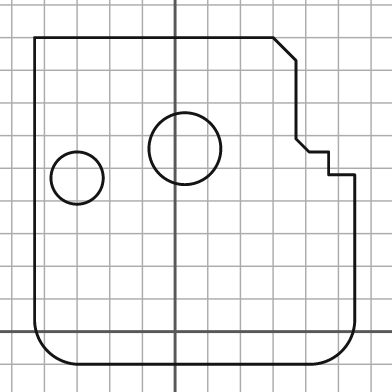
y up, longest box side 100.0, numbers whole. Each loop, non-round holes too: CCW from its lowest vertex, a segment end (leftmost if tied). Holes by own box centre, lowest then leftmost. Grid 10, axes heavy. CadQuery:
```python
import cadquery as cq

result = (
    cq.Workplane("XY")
    .moveTo(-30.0, -10.0)
    .lineTo(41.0, -10.0)
    .threePointArc((51.0, -6.0), (55.0, 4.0))
    .lineTo(55.0, 48.0)
    .lineTo(47.0, 48.0)
    .lineTo(47.0, 55.0)
    .lineTo(41.0, 55.0)
    .lineTo(37.0, 59.0)
    .lineTo(37.0, 83.0)
    .lineTo(30.0, 90.0)
    .lineTo(-43.0, 90.0)
    .lineTo(-43.0, 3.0)
    .threePointArc((-39.0, -6.0), (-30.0, -10.0))
    .close()
    .moveTo(-30.0, 47.0)
    .circle(8.0)
    .moveTo(3.0, 56.0)
    .circle(11.0)
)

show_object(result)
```